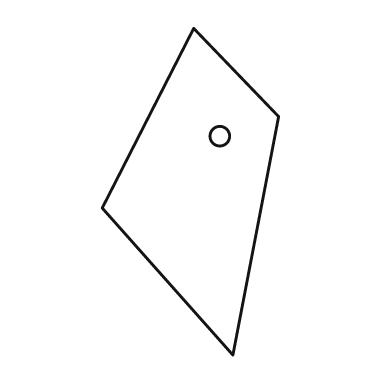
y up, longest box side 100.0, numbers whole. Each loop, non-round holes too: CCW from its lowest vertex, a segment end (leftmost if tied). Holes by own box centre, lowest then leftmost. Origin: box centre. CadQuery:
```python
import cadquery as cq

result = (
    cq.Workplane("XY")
    .moveTo(13.0, -50.0)
    .lineTo(27.0, 23.0)
    .lineTo(1.0, 50.0)
    .lineTo(-27.0, -5.0)
    .close()
    .moveTo(9.0, 17.0)
    .circle(3.0)
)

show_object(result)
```